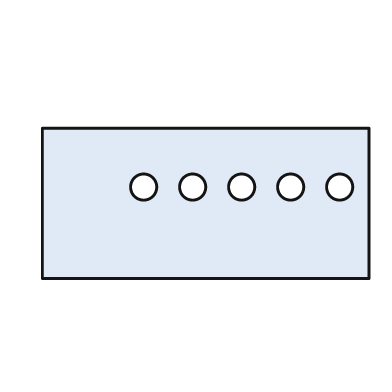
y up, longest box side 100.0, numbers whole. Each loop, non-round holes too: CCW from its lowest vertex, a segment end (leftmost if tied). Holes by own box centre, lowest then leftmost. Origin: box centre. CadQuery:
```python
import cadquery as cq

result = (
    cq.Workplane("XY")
    .moveTo(-50.0, -23.0)
    .lineTo(50.0, -23.0)
    .lineTo(50.0, 23.0)
    .lineTo(-50.0, 23.0)
    .close()
    .moveTo(-19.0, 5.0)
    .circle(4.0)
    .moveTo(-4.0, 5.0)
    .circle(4.0)
    .moveTo(11.0, 5.0)
    .circle(4.0)
    .moveTo(26.0, 5.0)
    .circle(4.0)
    .moveTo(41.0, 5.0)
    .circle(4.0)
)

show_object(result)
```